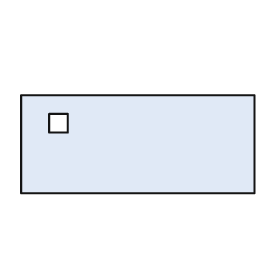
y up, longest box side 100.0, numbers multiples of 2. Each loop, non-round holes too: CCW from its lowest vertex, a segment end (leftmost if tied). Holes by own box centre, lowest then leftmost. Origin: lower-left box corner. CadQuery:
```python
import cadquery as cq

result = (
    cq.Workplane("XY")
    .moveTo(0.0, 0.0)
    .lineTo(100.0, 0.0)
    .lineTo(100.0, 42.0)
    .lineTo(0.0, 42.0)
    .close()
    .moveTo(12.0, 26.0)
    .lineTo(20.0, 26.0)
    .lineTo(20.0, 34.0)
    .lineTo(12.0, 34.0)
    .close()
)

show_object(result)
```